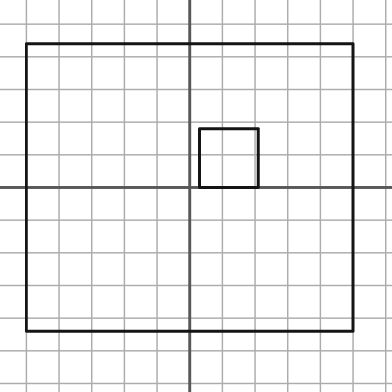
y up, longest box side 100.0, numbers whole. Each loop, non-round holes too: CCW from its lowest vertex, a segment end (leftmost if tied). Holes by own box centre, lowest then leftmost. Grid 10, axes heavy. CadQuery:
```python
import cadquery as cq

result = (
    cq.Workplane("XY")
    .moveTo(-50.0, -44.0)
    .lineTo(50.0, -44.0)
    .lineTo(50.0, 44.0)
    .lineTo(-50.0, 44.0)
    .close()
    .moveTo(3.0, 0.0)
    .lineTo(21.0, 0.0)
    .lineTo(21.0, 18.0)
    .lineTo(3.0, 18.0)
    .close()
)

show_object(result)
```